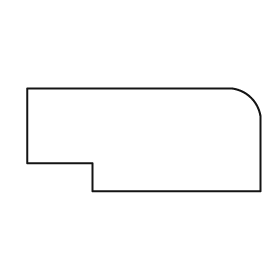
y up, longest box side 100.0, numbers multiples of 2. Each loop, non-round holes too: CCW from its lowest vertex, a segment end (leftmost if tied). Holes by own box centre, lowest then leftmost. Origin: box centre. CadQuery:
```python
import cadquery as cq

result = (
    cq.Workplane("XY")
    .moveTo(-22.0, -22.0)
    .lineTo(50.0, -22.0)
    .lineTo(50.0, 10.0)
    .threePointArc((46.0, 18.0), (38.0, 22.0))
    .lineTo(-50.0, 22.0)
    .lineTo(-50.0, -10.0)
    .lineTo(-22.0, -10.0)
    .close()
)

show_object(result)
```